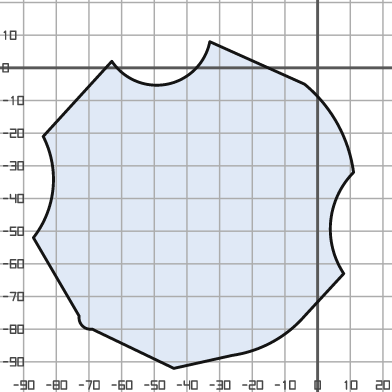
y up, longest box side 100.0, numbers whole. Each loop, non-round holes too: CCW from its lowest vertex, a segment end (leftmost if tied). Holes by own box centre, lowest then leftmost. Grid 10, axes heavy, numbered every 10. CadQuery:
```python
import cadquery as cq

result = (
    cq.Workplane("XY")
    .moveTo(-44.0, -92.0)
    .lineTo(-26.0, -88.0)
    .threePointArc((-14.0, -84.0), (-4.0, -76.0))
    .lineTo(8.0, -63.0)
    .threePointArc((4.0, -47.0), (11.0, -32.0))
    .threePointArc((6.0, -17.0), (-4.0, -5.0))
    .lineTo(-33.0, 8.0)
    .threePointArc((-46.0, -5.0), (-63.0, 2.0))
    .lineTo(-84.0, -21.0)
    .threePointArc((-81.0, -37.0), (-87.0, -52.0))
    .lineTo(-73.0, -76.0)
    .threePointArc((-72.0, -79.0), (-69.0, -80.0))
    .close()
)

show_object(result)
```